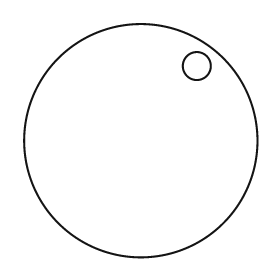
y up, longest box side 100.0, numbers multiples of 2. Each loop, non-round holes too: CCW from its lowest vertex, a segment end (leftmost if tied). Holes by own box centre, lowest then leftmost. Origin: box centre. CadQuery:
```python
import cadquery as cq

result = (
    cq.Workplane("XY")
    .moveTo(0.0, 0.0)
    .circle(50.0)
    .moveTo(24.0, 32.0)
    .circle(6.0)
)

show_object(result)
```